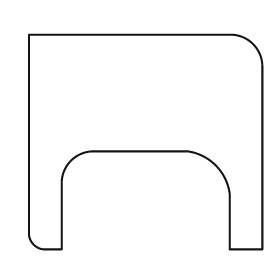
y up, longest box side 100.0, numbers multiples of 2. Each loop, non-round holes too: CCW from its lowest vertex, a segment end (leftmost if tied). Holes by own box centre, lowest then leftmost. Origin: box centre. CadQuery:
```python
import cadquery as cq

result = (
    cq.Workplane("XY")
    .moveTo(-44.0, -46.0)
    .lineTo(-36.0, -46.0)
    .lineTo(-36.0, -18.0)
    .threePointArc((-32.0, -8.0), (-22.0, -4.0))
    .lineTo(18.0, -4.0)
    .threePointArc((30.0, -10.0), (36.0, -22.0))
    .lineTo(36.0, -46.0)
    .lineTo(50.0, -46.0)
    .lineTo(50.0, 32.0)
    .threePointArc((46.0, 42.0), (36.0, 46.0))
    .lineTo(-50.0, 46.0)
    .lineTo(-50.0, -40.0)
    .threePointArc((-48.0, -44.0), (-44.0, -46.0))
    .close()
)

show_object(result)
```